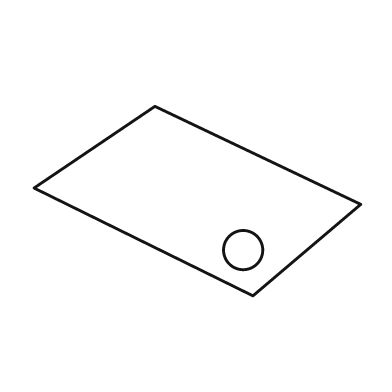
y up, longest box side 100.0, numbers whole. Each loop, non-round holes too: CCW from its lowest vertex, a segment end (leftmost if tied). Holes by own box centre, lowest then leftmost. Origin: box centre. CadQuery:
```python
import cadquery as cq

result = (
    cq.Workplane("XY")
    .moveTo(17.0, -29.0)
    .lineTo(50.0, -1.0)
    .lineTo(-13.0, 29.0)
    .lineTo(-50.0, 4.0)
    .close()
    .moveTo(14.0, -15.0)
    .circle(6.0)
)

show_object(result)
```